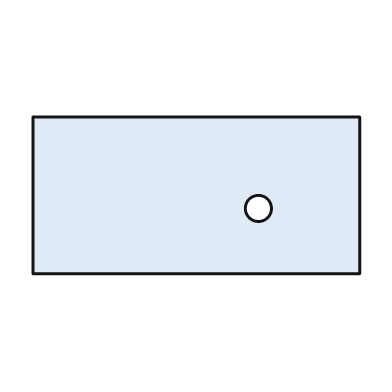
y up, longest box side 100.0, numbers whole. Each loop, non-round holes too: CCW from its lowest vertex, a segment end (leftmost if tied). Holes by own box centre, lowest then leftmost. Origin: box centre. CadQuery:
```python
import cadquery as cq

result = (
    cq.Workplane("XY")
    .moveTo(-50.0, -24.0)
    .lineTo(50.0, -24.0)
    .lineTo(50.0, 24.0)
    .lineTo(-50.0, 24.0)
    .close()
    .moveTo(19.0, -4.0)
    .circle(4.0)
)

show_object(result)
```